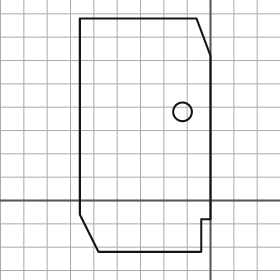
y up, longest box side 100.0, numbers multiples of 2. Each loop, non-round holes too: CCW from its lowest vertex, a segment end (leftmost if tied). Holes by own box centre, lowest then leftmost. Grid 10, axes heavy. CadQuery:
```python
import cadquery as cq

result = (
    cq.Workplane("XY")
    .moveTo(-48.0, -22.0)
    .lineTo(-4.0, -22.0)
    .lineTo(-4.0, -8.0)
    .lineTo(0.0, -8.0)
    .lineTo(0.0, 62.0)
    .lineTo(-6.0, 78.0)
    .lineTo(-56.0, 78.0)
    .lineTo(-56.0, -6.0)
    .close()
    .moveTo(-12.0, 38.0)
    .circle(4.0)
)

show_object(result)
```